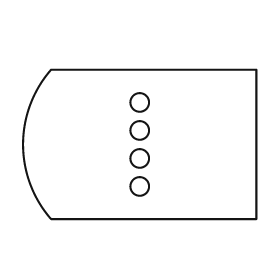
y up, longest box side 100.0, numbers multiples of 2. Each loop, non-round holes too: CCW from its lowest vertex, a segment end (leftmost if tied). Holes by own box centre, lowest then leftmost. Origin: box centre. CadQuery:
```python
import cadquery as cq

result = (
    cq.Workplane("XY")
    .moveTo(-38.0, -32.0)
    .lineTo(50.0, -32.0)
    .lineTo(50.0, 32.0)
    .lineTo(-38.0, 32.0)
    .threePointArc((-50.0, 0.0), (-38.0, -32.0))
    .close()
    .moveTo(0.0, -18.0)
    .circle(4.0)
    .moveTo(0.0, -6.0)
    .circle(4.0)
    .moveTo(0.0, 6.0)
    .circle(4.0)
    .moveTo(0.0, 18.0)
    .circle(4.0)
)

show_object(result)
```